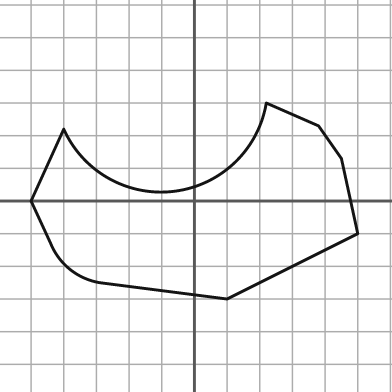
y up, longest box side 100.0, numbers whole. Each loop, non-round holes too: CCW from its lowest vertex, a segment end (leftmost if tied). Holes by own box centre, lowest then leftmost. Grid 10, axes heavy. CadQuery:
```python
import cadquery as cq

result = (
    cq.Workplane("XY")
    .moveTo(10.0, -30.0)
    .lineTo(50.0, -10.0)
    .lineTo(45.0, 13.0)
    .lineTo(38.0, 23.0)
    .lineTo(22.0, 30.0)
    .threePointArc((-6.0, 3.0), (-40.0, 22.0))
    .lineTo(-50.0, 0.0)
    .lineTo(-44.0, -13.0)
    .threePointArc((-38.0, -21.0), (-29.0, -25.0))
    .close()
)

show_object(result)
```